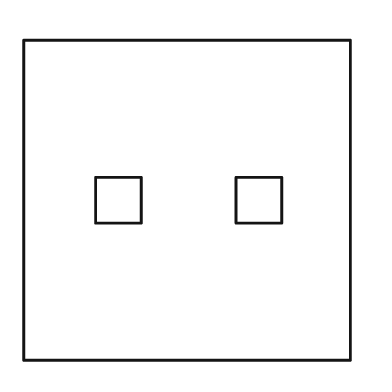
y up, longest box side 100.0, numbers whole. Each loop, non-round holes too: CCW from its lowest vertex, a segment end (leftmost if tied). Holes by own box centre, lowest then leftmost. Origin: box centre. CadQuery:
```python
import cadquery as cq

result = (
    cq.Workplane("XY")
    .moveTo(-50.0, -49.0)
    .lineTo(50.0, -49.0)
    .lineTo(50.0, 49.0)
    .lineTo(-50.0, 49.0)
    .close()
    .moveTo(-28.0, -7.0)
    .lineTo(-14.0, -7.0)
    .lineTo(-14.0, 7.0)
    .lineTo(-28.0, 7.0)
    .close()
    .moveTo(15.0, -7.0)
    .lineTo(29.0, -7.0)
    .lineTo(29.0, 7.0)
    .lineTo(15.0, 7.0)
    .close()
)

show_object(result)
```